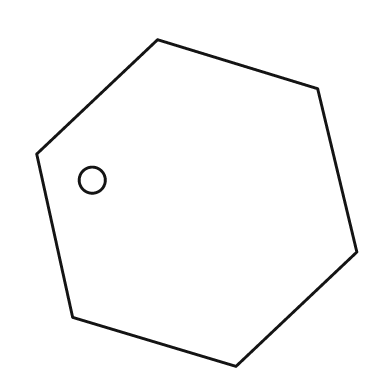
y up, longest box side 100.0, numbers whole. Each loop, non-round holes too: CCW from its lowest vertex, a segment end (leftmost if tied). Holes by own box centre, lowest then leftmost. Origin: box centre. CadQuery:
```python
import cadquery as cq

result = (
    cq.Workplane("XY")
    .moveTo(12.0, -50.0)
    .lineTo(49.0, -15.0)
    .lineTo(37.0, 35.0)
    .lineTo(-12.0, 50.0)
    .lineTo(-49.0, 15.0)
    .lineTo(-38.0, -35.0)
    .close()
    .moveTo(-32.0, 7.0)
    .circle(4.0)
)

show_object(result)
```